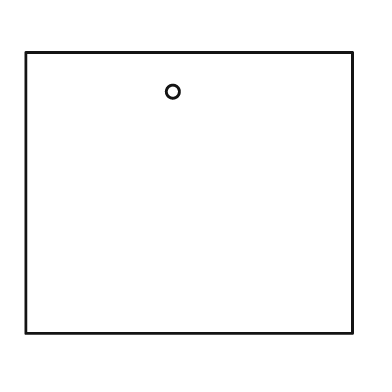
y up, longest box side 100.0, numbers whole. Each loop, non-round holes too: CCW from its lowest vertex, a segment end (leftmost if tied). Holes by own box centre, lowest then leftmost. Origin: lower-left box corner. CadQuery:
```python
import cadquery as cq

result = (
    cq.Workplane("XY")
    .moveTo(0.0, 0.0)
    .lineTo(100.0, 0.0)
    .lineTo(100.0, 86.0)
    .lineTo(0.0, 86.0)
    .close()
    .moveTo(45.0, 74.0)
    .circle(2.0)
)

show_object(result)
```